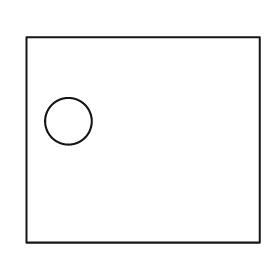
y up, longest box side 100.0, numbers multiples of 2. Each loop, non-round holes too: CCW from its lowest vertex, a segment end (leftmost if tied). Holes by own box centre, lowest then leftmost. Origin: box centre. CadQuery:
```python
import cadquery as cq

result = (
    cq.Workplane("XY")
    .moveTo(-50.0, -44.0)
    .lineTo(50.0, -44.0)
    .lineTo(50.0, 44.0)
    .lineTo(-50.0, 44.0)
    .close()
    .moveTo(-32.0, 8.0)
    .circle(10.0)
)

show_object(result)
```